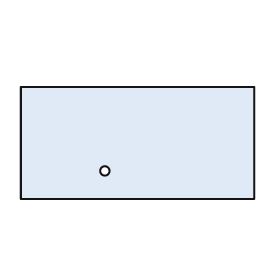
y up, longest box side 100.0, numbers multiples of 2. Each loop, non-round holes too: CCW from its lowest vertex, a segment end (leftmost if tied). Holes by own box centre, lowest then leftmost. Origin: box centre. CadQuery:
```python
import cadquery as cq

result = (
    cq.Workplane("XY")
    .moveTo(-50.0, -24.0)
    .lineTo(50.0, -24.0)
    .lineTo(50.0, 24.0)
    .lineTo(-50.0, 24.0)
    .close()
    .moveTo(-14.0, -12.0)
    .circle(2.0)
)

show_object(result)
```